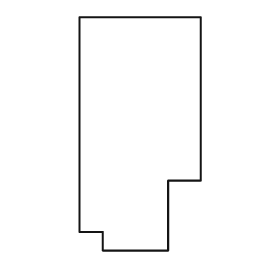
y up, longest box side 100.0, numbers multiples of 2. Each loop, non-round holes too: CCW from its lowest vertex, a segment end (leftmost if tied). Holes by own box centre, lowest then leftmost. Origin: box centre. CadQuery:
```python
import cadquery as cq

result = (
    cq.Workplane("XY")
    .moveTo(-16.0, -50.0)
    .lineTo(12.0, -50.0)
    .lineTo(12.0, -20.0)
    .lineTo(26.0, -20.0)
    .lineTo(26.0, 50.0)
    .lineTo(-26.0, 50.0)
    .lineTo(-26.0, -42.0)
    .lineTo(-16.0, -42.0)
    .close()
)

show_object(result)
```